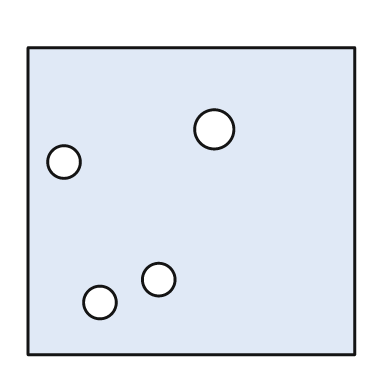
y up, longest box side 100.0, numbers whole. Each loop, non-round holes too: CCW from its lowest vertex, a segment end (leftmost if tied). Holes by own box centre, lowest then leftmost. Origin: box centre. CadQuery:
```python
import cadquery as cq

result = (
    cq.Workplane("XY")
    .moveTo(-50.0, -47.0)
    .lineTo(50.0, -47.0)
    .lineTo(50.0, 47.0)
    .lineTo(-50.0, 47.0)
    .close()
    .moveTo(-28.0, -31.0)
    .circle(5.0)
    .moveTo(-10.0, -24.0)
    .circle(5.0)
    .moveTo(-39.0, 12.0)
    .circle(5.0)
    .moveTo(7.0, 22.0)
    .circle(6.0)
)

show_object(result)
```